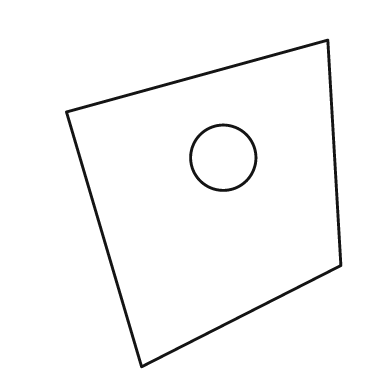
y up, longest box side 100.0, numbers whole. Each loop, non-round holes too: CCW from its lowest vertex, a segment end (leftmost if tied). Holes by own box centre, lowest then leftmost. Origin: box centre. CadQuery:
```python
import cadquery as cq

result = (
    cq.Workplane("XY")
    .moveTo(-19.0, -50.0)
    .lineTo(42.0, -19.0)
    .lineTo(38.0, 50.0)
    .lineTo(-42.0, 28.0)
    .close()
    .moveTo(6.0, 14.0)
    .circle(10.0)
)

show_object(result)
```